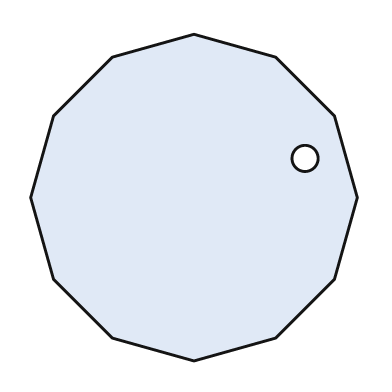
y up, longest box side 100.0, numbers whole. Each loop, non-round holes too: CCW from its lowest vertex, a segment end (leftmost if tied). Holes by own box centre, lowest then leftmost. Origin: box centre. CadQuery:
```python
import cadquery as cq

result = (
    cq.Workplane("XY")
    .moveTo(0.0, -50.0)
    .lineTo(25.0, -43.0)
    .lineTo(43.0, -25.0)
    .lineTo(50.0, 0.0)
    .lineTo(43.0, 25.0)
    .lineTo(25.0, 43.0)
    .lineTo(0.0, 50.0)
    .lineTo(-25.0, 43.0)
    .lineTo(-43.0, 25.0)
    .lineTo(-50.0, 0.0)
    .lineTo(-43.0, -25.0)
    .lineTo(-25.0, -43.0)
    .close()
    .moveTo(34.0, 12.0)
    .circle(4.0)
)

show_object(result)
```